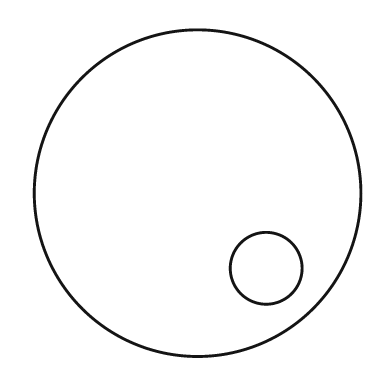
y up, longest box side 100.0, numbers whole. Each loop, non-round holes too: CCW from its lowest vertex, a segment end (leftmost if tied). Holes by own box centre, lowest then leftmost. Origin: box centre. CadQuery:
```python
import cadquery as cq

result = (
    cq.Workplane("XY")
    .moveTo(0.0, 0.0)
    .circle(50.0)
    .moveTo(21.0, -23.0)
    .circle(11.0)
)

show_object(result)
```